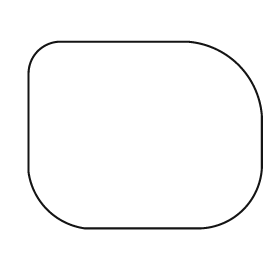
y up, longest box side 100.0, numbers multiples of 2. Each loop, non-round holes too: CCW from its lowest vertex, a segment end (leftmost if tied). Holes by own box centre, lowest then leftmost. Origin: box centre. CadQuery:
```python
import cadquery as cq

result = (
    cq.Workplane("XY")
    .moveTo(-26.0, -40.0)
    .lineTo(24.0, -40.0)
    .threePointArc((42.0, -32.0), (50.0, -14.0))
    .lineTo(50.0, 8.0)
    .threePointArc((40.0, 30.0), (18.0, 40.0))
    .lineTo(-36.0, 40.0)
    .threePointArc((-46.0, 36.0), (-50.0, 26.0))
    .lineTo(-50.0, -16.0)
    .threePointArc((-42.0, -32.0), (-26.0, -40.0))
    .close()
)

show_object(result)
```